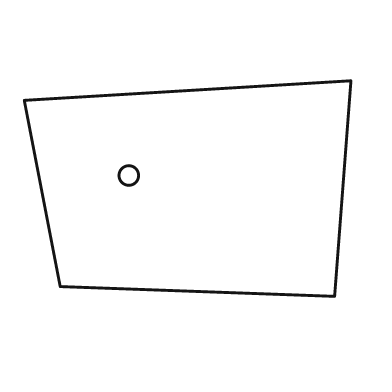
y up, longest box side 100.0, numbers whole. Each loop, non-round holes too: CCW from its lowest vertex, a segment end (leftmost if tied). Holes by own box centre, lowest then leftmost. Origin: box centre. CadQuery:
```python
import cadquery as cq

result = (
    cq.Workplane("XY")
    .moveTo(45.0, -33.0)
    .lineTo(50.0, 33.0)
    .lineTo(-50.0, 27.0)
    .lineTo(-39.0, -30.0)
    .close()
    .moveTo(-18.0, 4.0)
    .circle(3.0)
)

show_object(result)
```